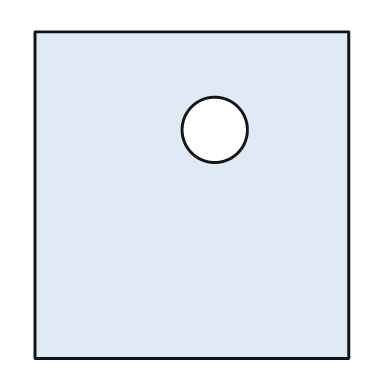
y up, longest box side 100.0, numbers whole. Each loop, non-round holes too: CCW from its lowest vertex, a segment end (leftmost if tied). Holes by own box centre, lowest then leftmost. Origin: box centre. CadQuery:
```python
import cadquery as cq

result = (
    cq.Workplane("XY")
    .moveTo(-48.0, -50.0)
    .lineTo(48.0, -50.0)
    .lineTo(48.0, 50.0)
    .lineTo(-48.0, 50.0)
    .close()
    .moveTo(7.0, 20.0)
    .circle(10.0)
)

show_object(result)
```